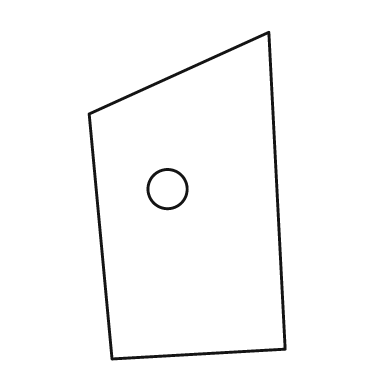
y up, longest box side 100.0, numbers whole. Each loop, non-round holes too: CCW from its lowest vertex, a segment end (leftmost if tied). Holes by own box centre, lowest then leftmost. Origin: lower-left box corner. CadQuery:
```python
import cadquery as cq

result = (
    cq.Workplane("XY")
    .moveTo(7.0, 0.0)
    .lineTo(60.0, 3.0)
    .lineTo(55.0, 100.0)
    .lineTo(0.0, 75.0)
    .close()
    .moveTo(24.0, 52.0)
    .circle(6.0)
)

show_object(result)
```